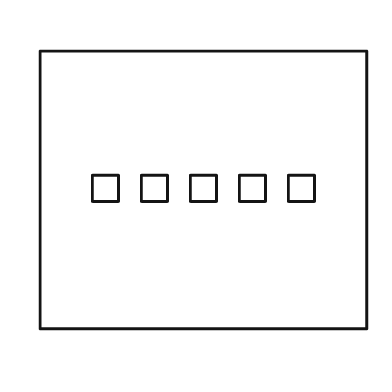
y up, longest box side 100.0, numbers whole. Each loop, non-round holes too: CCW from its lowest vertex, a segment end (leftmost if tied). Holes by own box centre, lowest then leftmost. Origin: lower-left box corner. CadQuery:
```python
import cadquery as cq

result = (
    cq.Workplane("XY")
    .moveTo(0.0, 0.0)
    .lineTo(100.0, 0.0)
    .lineTo(100.0, 85.0)
    .lineTo(0.0, 85.0)
    .close()
    .moveTo(16.0, 39.0)
    .lineTo(24.0, 39.0)
    .lineTo(24.0, 47.0)
    .lineTo(16.0, 47.0)
    .close()
    .moveTo(31.0, 39.0)
    .lineTo(39.0, 39.0)
    .lineTo(39.0, 47.0)
    .lineTo(31.0, 47.0)
    .close()
    .moveTo(46.0, 39.0)
    .lineTo(54.0, 39.0)
    .lineTo(54.0, 47.0)
    .lineTo(46.0, 47.0)
    .close()
    .moveTo(61.0, 39.0)
    .lineTo(69.0, 39.0)
    .lineTo(69.0, 47.0)
    .lineTo(61.0, 47.0)
    .close()
    .moveTo(76.0, 39.0)
    .lineTo(84.0, 39.0)
    .lineTo(84.0, 47.0)
    .lineTo(76.0, 47.0)
    .close()
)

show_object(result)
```